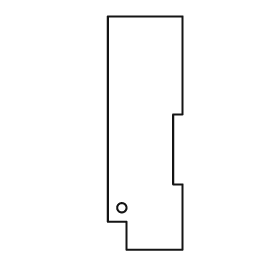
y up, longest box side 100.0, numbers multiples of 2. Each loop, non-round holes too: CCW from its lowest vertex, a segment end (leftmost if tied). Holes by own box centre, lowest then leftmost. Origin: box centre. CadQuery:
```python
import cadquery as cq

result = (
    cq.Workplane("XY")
    .moveTo(-8.0, -50.0)
    .lineTo(16.0, -50.0)
    .lineTo(16.0, -22.0)
    .lineTo(12.0, -22.0)
    .lineTo(12.0, 8.0)
    .lineTo(16.0, 8.0)
    .lineTo(16.0, 50.0)
    .lineTo(-16.0, 50.0)
    .lineTo(-16.0, -38.0)
    .lineTo(-8.0, -38.0)
    .close()
    .moveTo(-10.0, -32.0)
    .circle(2.0)
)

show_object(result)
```